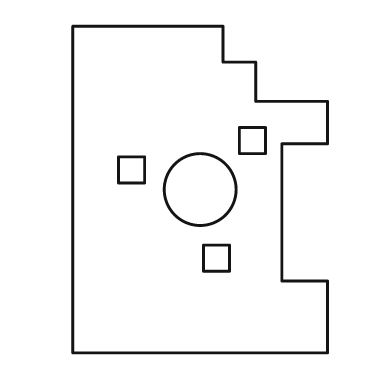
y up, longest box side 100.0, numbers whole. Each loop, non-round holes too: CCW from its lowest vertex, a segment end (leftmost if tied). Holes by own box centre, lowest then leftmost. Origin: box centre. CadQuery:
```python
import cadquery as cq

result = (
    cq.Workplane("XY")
    .moveTo(-39.0, -50.0)
    .lineTo(39.0, -50.0)
    .lineTo(39.0, -28.0)
    .lineTo(25.0, -28.0)
    .lineTo(25.0, 14.0)
    .lineTo(39.0, 14.0)
    .lineTo(39.0, 27.0)
    .lineTo(17.0, 27.0)
    .lineTo(17.0, 39.0)
    .lineTo(7.0, 39.0)
    .lineTo(7.0, 50.0)
    .lineTo(-39.0, 50.0)
    .close()
    .moveTo(1.0, -25.0)
    .lineTo(9.0, -25.0)
    .lineTo(9.0, -17.0)
    .lineTo(1.0, -17.0)
    .close()
    .moveTo(0.0, 0.0)
    .circle(11.0)
    .moveTo(-25.0, 2.0)
    .lineTo(-17.0, 2.0)
    .lineTo(-17.0, 10.0)
    .lineTo(-25.0, 10.0)
    .close()
    .moveTo(12.0, 11.0)
    .lineTo(20.0, 11.0)
    .lineTo(20.0, 19.0)
    .lineTo(12.0, 19.0)
    .close()
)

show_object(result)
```